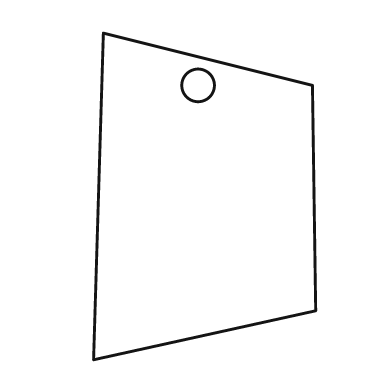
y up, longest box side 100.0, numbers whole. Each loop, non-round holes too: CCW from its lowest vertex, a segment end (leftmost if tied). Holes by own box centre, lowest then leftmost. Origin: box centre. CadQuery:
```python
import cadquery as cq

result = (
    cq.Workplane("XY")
    .moveTo(-34.0, -50.0)
    .lineTo(34.0, -35.0)
    .lineTo(33.0, 34.0)
    .lineTo(-31.0, 50.0)
    .close()
    .moveTo(-2.0, 34.0)
    .circle(5.0)
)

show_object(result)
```